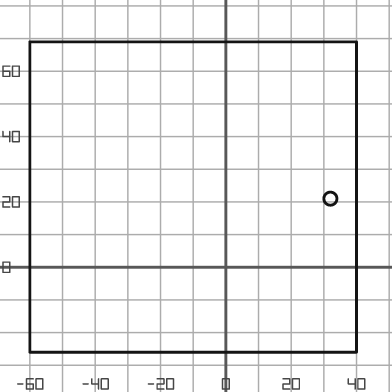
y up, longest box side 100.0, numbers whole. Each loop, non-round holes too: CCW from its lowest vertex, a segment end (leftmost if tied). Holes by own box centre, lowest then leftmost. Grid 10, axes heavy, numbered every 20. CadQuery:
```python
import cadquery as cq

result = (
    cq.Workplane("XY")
    .moveTo(-60.0, -26.0)
    .lineTo(40.0, -26.0)
    .lineTo(40.0, 69.0)
    .lineTo(-60.0, 69.0)
    .close()
    .moveTo(32.0, 21.0)
    .circle(2.0)
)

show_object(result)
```